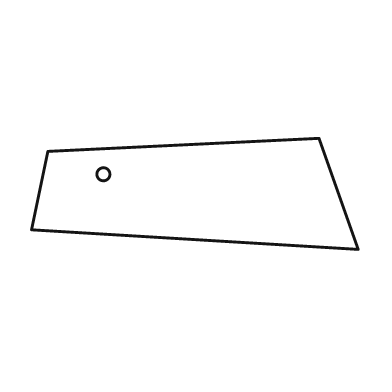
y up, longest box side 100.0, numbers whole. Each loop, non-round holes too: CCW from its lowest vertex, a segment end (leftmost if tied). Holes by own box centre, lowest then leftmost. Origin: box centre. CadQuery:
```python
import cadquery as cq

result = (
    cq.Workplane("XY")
    .moveTo(50.0, -17.0)
    .lineTo(38.0, 17.0)
    .lineTo(-45.0, 13.0)
    .lineTo(-50.0, -11.0)
    .close()
    .moveTo(-28.0, 6.0)
    .circle(2.0)
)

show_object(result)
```